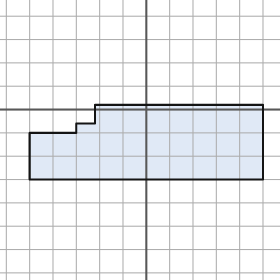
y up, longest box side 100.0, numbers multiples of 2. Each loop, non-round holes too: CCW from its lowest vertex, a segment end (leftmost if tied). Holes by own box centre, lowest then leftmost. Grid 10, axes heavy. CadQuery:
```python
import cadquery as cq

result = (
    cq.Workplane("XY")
    .moveTo(-50.0, -30.0)
    .lineTo(50.0, -30.0)
    .lineTo(50.0, 2.0)
    .lineTo(-22.0, 2.0)
    .lineTo(-22.0, -6.0)
    .lineTo(-30.0, -6.0)
    .lineTo(-30.0, -10.0)
    .lineTo(-50.0, -10.0)
    .close()
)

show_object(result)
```